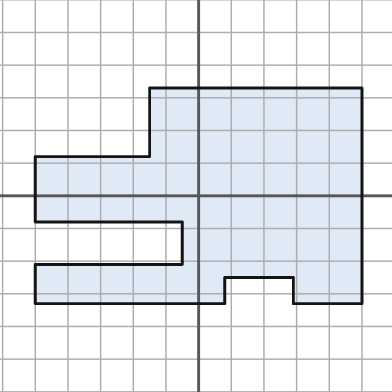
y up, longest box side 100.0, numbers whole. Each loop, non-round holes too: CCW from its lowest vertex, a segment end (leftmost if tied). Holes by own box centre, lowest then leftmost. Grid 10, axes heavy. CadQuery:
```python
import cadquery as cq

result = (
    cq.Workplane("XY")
    .moveTo(-50.0, -33.0)
    .lineTo(8.0, -33.0)
    .lineTo(8.0, -25.0)
    .lineTo(29.0, -25.0)
    .lineTo(29.0, -33.0)
    .lineTo(50.0, -33.0)
    .lineTo(50.0, 33.0)
    .lineTo(-15.0, 33.0)
    .lineTo(-15.0, 12.0)
    .lineTo(-50.0, 12.0)
    .lineTo(-50.0, -8.0)
    .lineTo(-5.0, -8.0)
    .lineTo(-5.0, -21.0)
    .lineTo(-50.0, -21.0)
    .close()
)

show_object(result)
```